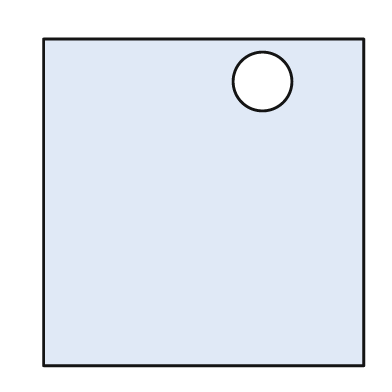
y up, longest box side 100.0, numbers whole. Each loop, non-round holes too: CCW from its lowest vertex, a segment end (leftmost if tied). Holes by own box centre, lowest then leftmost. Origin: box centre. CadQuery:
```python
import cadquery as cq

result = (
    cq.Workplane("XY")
    .moveTo(-49.0, -50.0)
    .lineTo(49.0, -50.0)
    .lineTo(49.0, 50.0)
    .lineTo(-49.0, 50.0)
    .close()
    .moveTo(18.0, 37.0)
    .circle(9.0)
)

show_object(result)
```